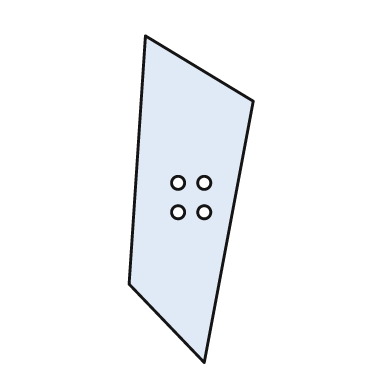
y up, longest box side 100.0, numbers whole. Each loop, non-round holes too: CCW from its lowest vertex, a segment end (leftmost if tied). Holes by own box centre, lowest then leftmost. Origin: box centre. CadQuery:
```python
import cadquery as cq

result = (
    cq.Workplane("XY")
    .moveTo(4.0, -50.0)
    .lineTo(19.0, 30.0)
    .lineTo(-14.0, 50.0)
    .lineTo(-19.0, -26.0)
    .close()
    .moveTo(-4.0, -4.0)
    .circle(2.0)
    .moveTo(4.0, -4.0)
    .circle(2.0)
    .moveTo(-4.0, 5.0)
    .circle(2.0)
    .moveTo(4.0, 5.0)
    .circle(2.0)
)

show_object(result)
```